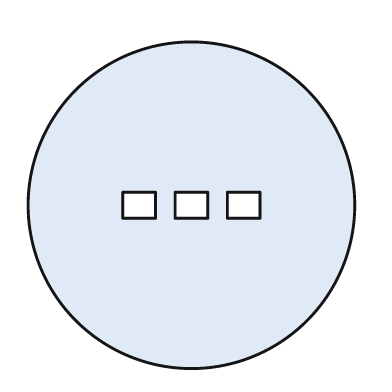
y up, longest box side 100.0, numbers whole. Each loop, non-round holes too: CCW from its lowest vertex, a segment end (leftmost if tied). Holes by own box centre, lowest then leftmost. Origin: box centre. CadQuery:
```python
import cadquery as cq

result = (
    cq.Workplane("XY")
    .moveTo(0.0, 0.0)
    .circle(50.0)
    .moveTo(-21.0, -4.0)
    .lineTo(-11.0, -4.0)
    .lineTo(-11.0, 4.0)
    .lineTo(-21.0, 4.0)
    .close()
    .moveTo(-5.0, -4.0)
    .lineTo(5.0, -4.0)
    .lineTo(5.0, 4.0)
    .lineTo(-5.0, 4.0)
    .close()
    .moveTo(11.0, -4.0)
    .lineTo(21.0, -4.0)
    .lineTo(21.0, 4.0)
    .lineTo(11.0, 4.0)
    .close()
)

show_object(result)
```